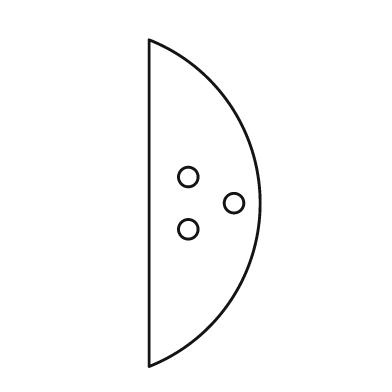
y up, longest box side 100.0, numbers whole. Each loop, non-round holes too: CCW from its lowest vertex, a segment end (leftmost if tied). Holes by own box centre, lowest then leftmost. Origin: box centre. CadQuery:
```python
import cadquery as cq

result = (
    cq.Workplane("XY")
    .moveTo(-17.0, -50.0)
    .threePointArc((17.0, 0.0), (-17.0, 50.0))
    .close()
    .moveTo(-5.0, -8.0)
    .circle(3.0)
    .moveTo(9.0, 0.0)
    .circle(3.0)
    .moveTo(-5.0, 8.0)
    .circle(3.0)
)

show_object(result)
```